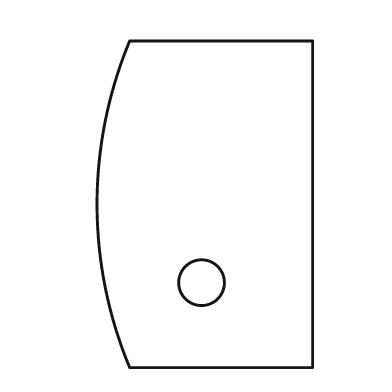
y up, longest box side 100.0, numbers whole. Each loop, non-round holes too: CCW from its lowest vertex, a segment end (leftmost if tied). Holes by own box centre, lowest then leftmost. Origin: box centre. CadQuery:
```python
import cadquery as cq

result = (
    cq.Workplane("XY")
    .moveTo(-23.0, -50.0)
    .lineTo(33.0, -50.0)
    .lineTo(33.0, 50.0)
    .lineTo(-23.0, 50.0)
    .threePointArc((-33.0, 0.0), (-23.0, -50.0))
    .close()
    .moveTo(-1.0, -24.0)
    .circle(7.0)
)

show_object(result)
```